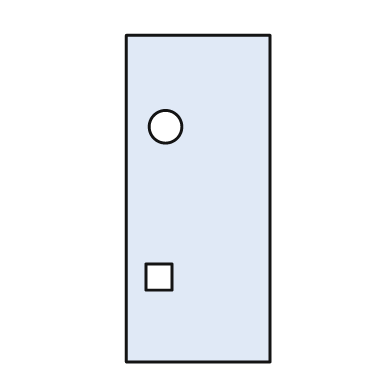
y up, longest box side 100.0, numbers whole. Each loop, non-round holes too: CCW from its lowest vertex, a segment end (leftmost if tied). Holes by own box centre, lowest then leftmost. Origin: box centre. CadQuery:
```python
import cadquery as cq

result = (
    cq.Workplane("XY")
    .moveTo(-22.0, -50.0)
    .lineTo(22.0, -50.0)
    .lineTo(22.0, 50.0)
    .lineTo(-22.0, 50.0)
    .close()
    .moveTo(-16.0, -28.0)
    .lineTo(-8.0, -28.0)
    .lineTo(-8.0, -20.0)
    .lineTo(-16.0, -20.0)
    .close()
    .moveTo(-10.0, 22.0)
    .circle(5.0)
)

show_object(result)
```